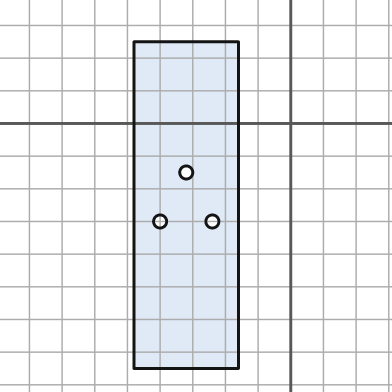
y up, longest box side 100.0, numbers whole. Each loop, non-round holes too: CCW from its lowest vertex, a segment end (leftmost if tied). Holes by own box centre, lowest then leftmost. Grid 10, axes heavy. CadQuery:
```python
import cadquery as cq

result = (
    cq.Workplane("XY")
    .moveTo(-48.0, -75.0)
    .lineTo(-16.0, -75.0)
    .lineTo(-16.0, 25.0)
    .lineTo(-48.0, 25.0)
    .close()
    .moveTo(-40.0, -30.0)
    .circle(2.0)
    .moveTo(-24.0, -30.0)
    .circle(2.0)
    .moveTo(-32.0, -15.0)
    .circle(2.0)
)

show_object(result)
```